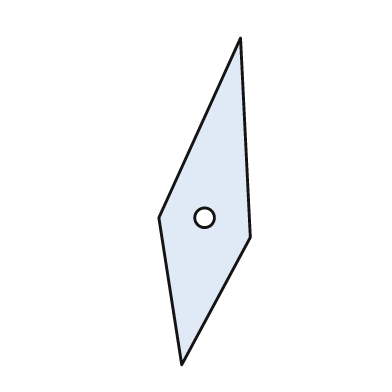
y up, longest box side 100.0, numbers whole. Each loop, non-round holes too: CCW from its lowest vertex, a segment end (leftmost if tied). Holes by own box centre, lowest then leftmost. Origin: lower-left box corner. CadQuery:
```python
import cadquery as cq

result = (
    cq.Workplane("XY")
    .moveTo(7.0, 0.0)
    .lineTo(28.0, 39.0)
    .lineTo(25.0, 100.0)
    .lineTo(0.0, 45.0)
    .close()
    .moveTo(14.0, 45.0)
    .circle(3.0)
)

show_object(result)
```